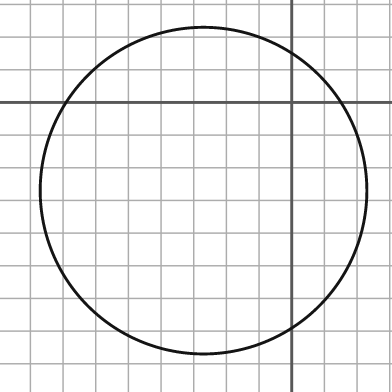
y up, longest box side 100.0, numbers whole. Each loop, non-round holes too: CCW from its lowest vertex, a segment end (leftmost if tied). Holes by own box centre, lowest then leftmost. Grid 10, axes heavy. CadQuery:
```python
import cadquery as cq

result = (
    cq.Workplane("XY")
    .moveTo(-27.0, -27.0)
    .circle(50.0)
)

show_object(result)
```